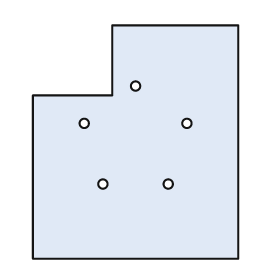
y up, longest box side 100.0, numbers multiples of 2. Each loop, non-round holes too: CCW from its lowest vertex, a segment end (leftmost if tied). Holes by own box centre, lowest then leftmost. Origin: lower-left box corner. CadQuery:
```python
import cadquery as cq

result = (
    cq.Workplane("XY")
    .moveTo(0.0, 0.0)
    .lineTo(88.0, 0.0)
    .lineTo(88.0, 100.0)
    .lineTo(34.0, 100.0)
    .lineTo(34.0, 70.0)
    .lineTo(0.0, 70.0)
    .close()
    .moveTo(30.0, 32.0)
    .circle(2.0)
    .moveTo(58.0, 32.0)
    .circle(2.0)
    .moveTo(22.0, 58.0)
    .circle(2.0)
    .moveTo(66.0, 58.0)
    .circle(2.0)
    .moveTo(44.0, 74.0)
    .circle(2.0)
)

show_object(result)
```